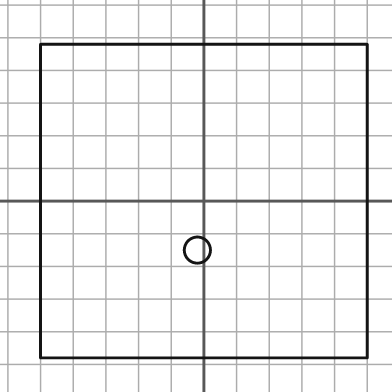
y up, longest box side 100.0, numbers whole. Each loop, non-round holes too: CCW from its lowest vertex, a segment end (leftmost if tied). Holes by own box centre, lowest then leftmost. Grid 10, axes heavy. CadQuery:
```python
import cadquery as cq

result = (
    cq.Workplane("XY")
    .moveTo(-50.0, -48.0)
    .lineTo(50.0, -48.0)
    .lineTo(50.0, 48.0)
    .lineTo(-50.0, 48.0)
    .close()
    .moveTo(-2.0, -15.0)
    .circle(4.0)
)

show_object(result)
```